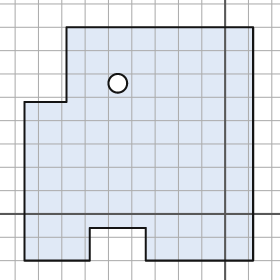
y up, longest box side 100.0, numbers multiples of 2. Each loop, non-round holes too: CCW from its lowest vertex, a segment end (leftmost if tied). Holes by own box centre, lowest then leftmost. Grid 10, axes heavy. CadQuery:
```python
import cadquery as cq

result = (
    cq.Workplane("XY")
    .moveTo(-86.0, -20.0)
    .lineTo(-58.0, -20.0)
    .lineTo(-58.0, -6.0)
    .lineTo(-34.0, -6.0)
    .lineTo(-34.0, -20.0)
    .lineTo(12.0, -20.0)
    .lineTo(12.0, 80.0)
    .lineTo(-68.0, 80.0)
    .lineTo(-68.0, 48.0)
    .lineTo(-86.0, 48.0)
    .close()
    .moveTo(-46.0, 56.0)
    .circle(4.0)
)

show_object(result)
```